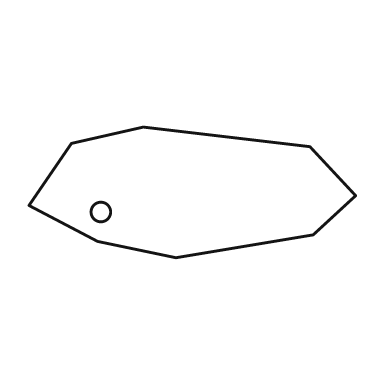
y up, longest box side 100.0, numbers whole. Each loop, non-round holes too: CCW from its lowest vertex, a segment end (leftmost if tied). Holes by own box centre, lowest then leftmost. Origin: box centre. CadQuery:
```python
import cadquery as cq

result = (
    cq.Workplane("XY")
    .moveTo(-5.0, -20.0)
    .lineTo(37.0, -13.0)
    .lineTo(50.0, -1.0)
    .lineTo(36.0, 14.0)
    .lineTo(-15.0, 20.0)
    .lineTo(-37.0, 15.0)
    .lineTo(-50.0, -4.0)
    .lineTo(-29.0, -15.0)
    .close()
    .moveTo(-28.0, -6.0)
    .circle(3.0)
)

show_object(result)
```